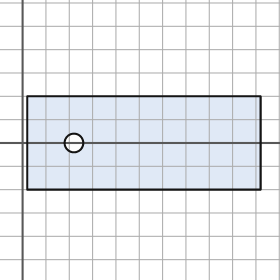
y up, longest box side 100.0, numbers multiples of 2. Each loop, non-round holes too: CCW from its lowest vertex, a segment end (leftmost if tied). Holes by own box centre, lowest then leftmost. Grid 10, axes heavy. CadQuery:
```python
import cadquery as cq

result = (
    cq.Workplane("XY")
    .moveTo(2.0, -20.0)
    .lineTo(102.0, -20.0)
    .lineTo(102.0, 20.0)
    .lineTo(2.0, 20.0)
    .close()
    .moveTo(22.0, 0.0)
    .circle(4.0)
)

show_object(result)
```